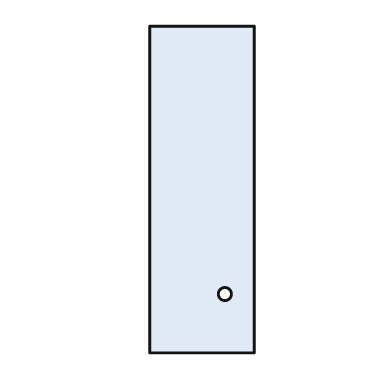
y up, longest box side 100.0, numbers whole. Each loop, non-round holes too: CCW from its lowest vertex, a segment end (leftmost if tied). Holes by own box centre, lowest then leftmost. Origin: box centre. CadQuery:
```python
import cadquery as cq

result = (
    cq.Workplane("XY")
    .moveTo(-16.0, -50.0)
    .lineTo(16.0, -50.0)
    .lineTo(16.0, 50.0)
    .lineTo(-16.0, 50.0)
    .close()
    .moveTo(7.0, -32.0)
    .circle(2.0)
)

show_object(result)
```